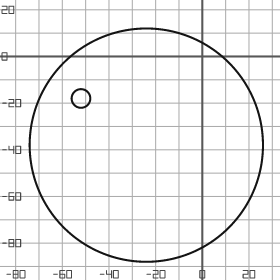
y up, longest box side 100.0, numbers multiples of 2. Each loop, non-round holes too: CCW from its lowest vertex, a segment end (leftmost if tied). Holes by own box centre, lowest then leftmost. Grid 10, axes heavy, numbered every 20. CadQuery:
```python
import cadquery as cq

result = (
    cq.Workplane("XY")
    .moveTo(-24.0, -38.0)
    .circle(50.0)
    .moveTo(-52.0, -18.0)
    .circle(4.0)
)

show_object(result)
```